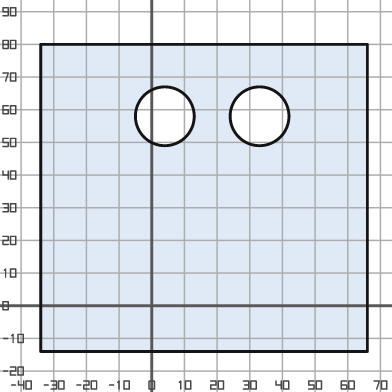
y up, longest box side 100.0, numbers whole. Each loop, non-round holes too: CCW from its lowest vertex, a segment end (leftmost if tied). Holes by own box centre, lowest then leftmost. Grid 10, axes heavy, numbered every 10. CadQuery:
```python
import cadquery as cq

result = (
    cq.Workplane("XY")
    .moveTo(-34.0, -14.0)
    .lineTo(66.0, -14.0)
    .lineTo(66.0, 80.0)
    .lineTo(-34.0, 80.0)
    .close()
    .moveTo(4.0, 58.0)
    .circle(9.0)
    .moveTo(33.0, 58.0)
    .circle(9.0)
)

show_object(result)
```